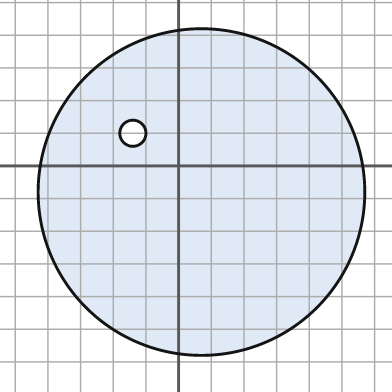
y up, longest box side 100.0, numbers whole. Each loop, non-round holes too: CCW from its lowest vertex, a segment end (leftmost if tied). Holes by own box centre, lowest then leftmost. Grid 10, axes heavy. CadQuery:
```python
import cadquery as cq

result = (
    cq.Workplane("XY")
    .moveTo(7.0, -8.0)
    .circle(50.0)
    .moveTo(-14.0, 10.0)
    .circle(4.0)
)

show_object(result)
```